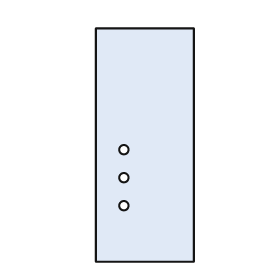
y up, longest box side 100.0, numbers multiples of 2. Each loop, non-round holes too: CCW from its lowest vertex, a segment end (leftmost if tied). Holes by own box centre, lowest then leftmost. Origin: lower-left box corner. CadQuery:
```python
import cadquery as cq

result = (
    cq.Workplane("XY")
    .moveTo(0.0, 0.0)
    .lineTo(42.0, 0.0)
    .lineTo(42.0, 100.0)
    .lineTo(0.0, 100.0)
    .close()
    .moveTo(12.0, 24.0)
    .circle(2.0)
    .moveTo(12.0, 36.0)
    .circle(2.0)
    .moveTo(12.0, 48.0)
    .circle(2.0)
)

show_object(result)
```